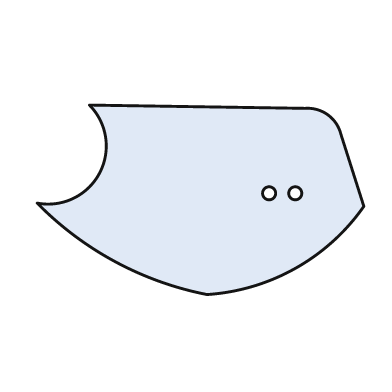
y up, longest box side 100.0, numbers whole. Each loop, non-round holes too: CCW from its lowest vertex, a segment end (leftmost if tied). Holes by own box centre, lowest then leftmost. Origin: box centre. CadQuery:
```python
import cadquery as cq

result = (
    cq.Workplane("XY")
    .moveTo(2.0, -29.0)
    .threePointArc((29.0, -21.0), (50.0, -2.0))
    .lineTo(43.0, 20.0)
    .threePointArc((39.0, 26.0), (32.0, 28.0))
    .lineTo(-34.0, 29.0)
    .threePointArc((-31.0, 8.0), (-50.0, -1.0))
    .threePointArc((-26.0, -19.0), (2.0, -29.0))
    .close()
    .moveTo(21.0, 2.0)
    .circle(2.0)
    .moveTo(29.0, 2.0)
    .circle(2.0)
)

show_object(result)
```